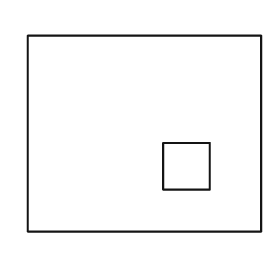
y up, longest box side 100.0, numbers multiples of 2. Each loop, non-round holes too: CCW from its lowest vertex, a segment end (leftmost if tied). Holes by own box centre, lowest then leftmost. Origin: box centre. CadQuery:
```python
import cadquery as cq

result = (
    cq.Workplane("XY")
    .moveTo(-50.0, -42.0)
    .lineTo(50.0, -42.0)
    .lineTo(50.0, 42.0)
    .lineTo(-50.0, 42.0)
    .close()
    .moveTo(8.0, -24.0)
    .lineTo(28.0, -24.0)
    .lineTo(28.0, -4.0)
    .lineTo(8.0, -4.0)
    .close()
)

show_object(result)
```